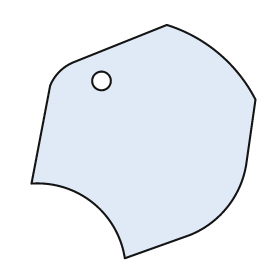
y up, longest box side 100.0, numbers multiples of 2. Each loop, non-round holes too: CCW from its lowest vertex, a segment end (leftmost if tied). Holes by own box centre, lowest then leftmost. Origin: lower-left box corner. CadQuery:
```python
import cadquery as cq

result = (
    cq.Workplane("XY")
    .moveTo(40.0, 0.0)
    .lineTo(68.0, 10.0)
    .threePointArc((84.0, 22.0), (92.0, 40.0))
    .lineTo(96.0, 68.0)
    .threePointArc((80.0, 88.0), (58.0, 100.0))
    .lineTo(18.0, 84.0)
    .threePointArc((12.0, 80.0), (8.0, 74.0))
    .lineTo(0.0, 32.0)
    .threePointArc((26.0, 24.0), (40.0, 0.0))
    .close()
    .moveTo(30.0, 76.0)
    .circle(4.0)
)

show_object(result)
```